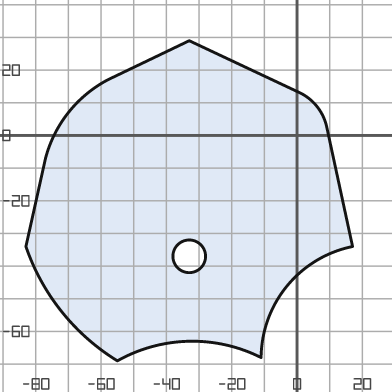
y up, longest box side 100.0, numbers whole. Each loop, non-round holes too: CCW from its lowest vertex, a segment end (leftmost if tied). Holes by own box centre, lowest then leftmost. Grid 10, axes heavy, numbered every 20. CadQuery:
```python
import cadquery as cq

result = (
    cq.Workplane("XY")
    .moveTo(-55.0, -69.0)
    .threePointArc((-33.0, -63.0), (-11.0, -68.0))
    .threePointArc((-3.0, -46.0), (17.0, -34.0))
    .lineTo(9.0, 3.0)
    .threePointArc((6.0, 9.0), (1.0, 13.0))
    .lineTo(-33.0, 29.0)
    .lineTo(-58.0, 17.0)
    .threePointArc((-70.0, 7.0), (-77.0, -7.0))
    .lineTo(-83.0, -34.0)
    .threePointArc((-72.0, -54.0), (-55.0, -69.0))
    .close()
    .moveTo(-33.0, -37.0)
    .circle(5.0)
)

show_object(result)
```